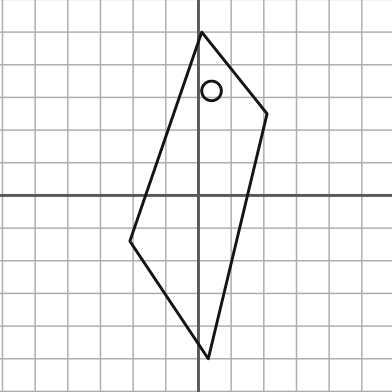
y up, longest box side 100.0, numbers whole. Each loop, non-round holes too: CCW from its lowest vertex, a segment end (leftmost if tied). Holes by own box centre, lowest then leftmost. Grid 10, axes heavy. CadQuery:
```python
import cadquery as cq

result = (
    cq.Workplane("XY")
    .moveTo(3.0, -50.0)
    .lineTo(21.0, 25.0)
    .lineTo(1.0, 50.0)
    .lineTo(-21.0, -14.0)
    .close()
    .moveTo(4.0, 32.0)
    .circle(3.0)
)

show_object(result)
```